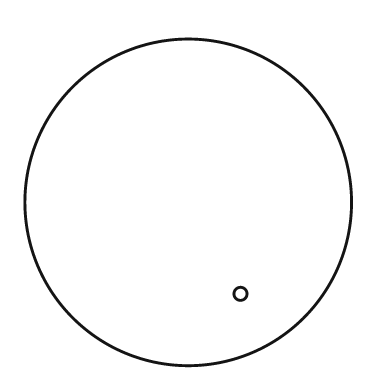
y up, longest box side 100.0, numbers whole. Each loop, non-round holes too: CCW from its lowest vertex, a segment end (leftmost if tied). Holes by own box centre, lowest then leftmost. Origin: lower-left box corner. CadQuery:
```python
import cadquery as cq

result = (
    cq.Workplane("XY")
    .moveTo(50.0, 50.0)
    .circle(50.0)
    .moveTo(66.0, 22.0)
    .circle(2.0)
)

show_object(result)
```